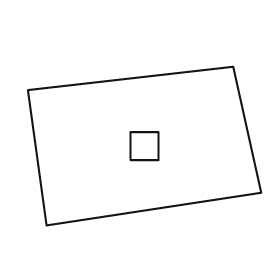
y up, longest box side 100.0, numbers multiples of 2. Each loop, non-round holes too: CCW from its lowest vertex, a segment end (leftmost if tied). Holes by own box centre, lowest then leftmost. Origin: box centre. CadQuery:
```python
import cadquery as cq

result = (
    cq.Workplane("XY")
    .moveTo(-42.0, -34.0)
    .lineTo(50.0, -20.0)
    .lineTo(38.0, 34.0)
    .lineTo(-50.0, 24.0)
    .close()
    .moveTo(-6.0, -6.0)
    .lineTo(6.0, -6.0)
    .lineTo(6.0, 6.0)
    .lineTo(-6.0, 6.0)
    .close()
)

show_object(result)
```